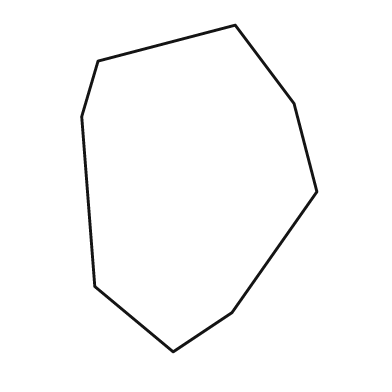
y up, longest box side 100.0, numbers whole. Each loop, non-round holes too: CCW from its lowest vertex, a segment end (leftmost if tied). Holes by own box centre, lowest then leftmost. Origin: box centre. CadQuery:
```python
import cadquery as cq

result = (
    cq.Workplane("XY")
    .moveTo(-8.0, -50.0)
    .lineTo(10.0, -38.0)
    .lineTo(36.0, -1.0)
    .lineTo(29.0, 26.0)
    .lineTo(11.0, 50.0)
    .lineTo(-31.0, 39.0)
    .lineTo(-36.0, 22.0)
    .lineTo(-32.0, -30.0)
    .close()
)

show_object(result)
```